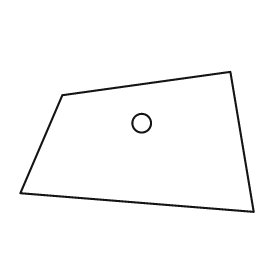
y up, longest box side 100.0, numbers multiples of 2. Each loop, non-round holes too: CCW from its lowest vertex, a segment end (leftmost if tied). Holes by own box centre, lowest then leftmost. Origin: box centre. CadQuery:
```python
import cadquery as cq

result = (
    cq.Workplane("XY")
    .moveTo(50.0, -30.0)
    .lineTo(40.0, 30.0)
    .lineTo(-32.0, 20.0)
    .lineTo(-50.0, -22.0)
    .close()
    .moveTo(2.0, 8.0)
    .circle(4.0)
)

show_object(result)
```